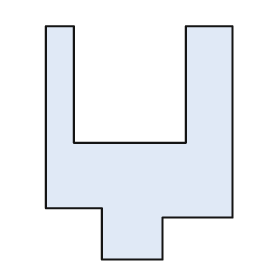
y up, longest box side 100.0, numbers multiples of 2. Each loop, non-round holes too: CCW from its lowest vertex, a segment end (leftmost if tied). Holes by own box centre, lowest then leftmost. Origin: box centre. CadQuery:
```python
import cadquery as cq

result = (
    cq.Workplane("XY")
    .moveTo(-16.0, -50.0)
    .lineTo(10.0, -50.0)
    .lineTo(10.0, -32.0)
    .lineTo(40.0, -32.0)
    .lineTo(40.0, 50.0)
    .lineTo(20.0, 50.0)
    .lineTo(20.0, 0.0)
    .lineTo(-28.0, 0.0)
    .lineTo(-28.0, 50.0)
    .lineTo(-40.0, 50.0)
    .lineTo(-40.0, -28.0)
    .lineTo(-16.0, -28.0)
    .close()
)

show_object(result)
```